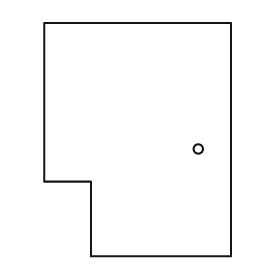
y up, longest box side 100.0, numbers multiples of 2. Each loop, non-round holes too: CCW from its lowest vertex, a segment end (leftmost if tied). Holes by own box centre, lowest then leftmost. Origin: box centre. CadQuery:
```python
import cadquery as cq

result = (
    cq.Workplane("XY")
    .moveTo(-20.0, -50.0)
    .lineTo(40.0, -50.0)
    .lineTo(40.0, 50.0)
    .lineTo(-40.0, 50.0)
    .lineTo(-40.0, -18.0)
    .lineTo(-20.0, -18.0)
    .close()
    .moveTo(26.0, -4.0)
    .circle(2.0)
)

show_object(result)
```